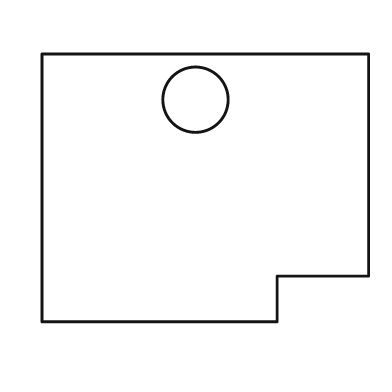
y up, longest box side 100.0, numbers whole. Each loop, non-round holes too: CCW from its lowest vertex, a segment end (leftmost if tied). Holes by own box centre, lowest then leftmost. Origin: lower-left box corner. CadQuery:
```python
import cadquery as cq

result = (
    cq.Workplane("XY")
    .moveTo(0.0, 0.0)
    .lineTo(72.0, 0.0)
    .lineTo(72.0, 14.0)
    .lineTo(100.0, 14.0)
    .lineTo(100.0, 82.0)
    .lineTo(0.0, 82.0)
    .close()
    .moveTo(47.0, 68.0)
    .circle(10.0)
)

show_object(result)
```